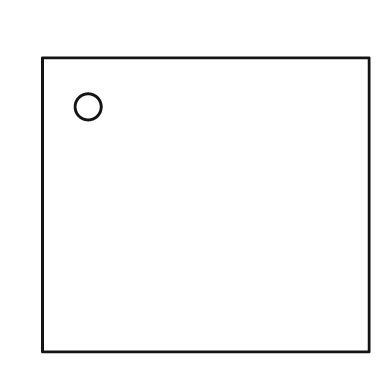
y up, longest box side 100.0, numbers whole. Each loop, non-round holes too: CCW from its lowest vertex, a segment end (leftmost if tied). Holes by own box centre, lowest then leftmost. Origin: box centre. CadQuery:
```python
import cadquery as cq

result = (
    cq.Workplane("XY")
    .moveTo(-50.0, -45.0)
    .lineTo(50.0, -45.0)
    .lineTo(50.0, 45.0)
    .lineTo(-50.0, 45.0)
    .close()
    .moveTo(-36.0, 30.0)
    .circle(4.0)
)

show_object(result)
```